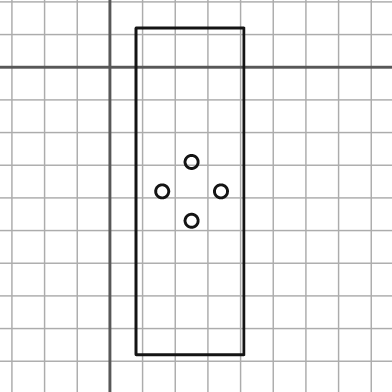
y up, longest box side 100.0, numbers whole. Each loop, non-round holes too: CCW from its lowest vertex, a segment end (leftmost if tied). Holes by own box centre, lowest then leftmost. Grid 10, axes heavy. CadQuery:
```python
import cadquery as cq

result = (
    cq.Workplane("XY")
    .moveTo(8.0, -88.0)
    .lineTo(41.0, -88.0)
    .lineTo(41.0, 12.0)
    .lineTo(8.0, 12.0)
    .close()
    .moveTo(25.0, -47.0)
    .circle(2.0)
    .moveTo(16.0, -38.0)
    .circle(2.0)
    .moveTo(34.0, -38.0)
    .circle(2.0)
    .moveTo(25.0, -29.0)
    .circle(2.0)
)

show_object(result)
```